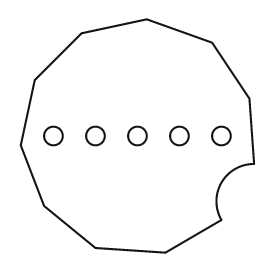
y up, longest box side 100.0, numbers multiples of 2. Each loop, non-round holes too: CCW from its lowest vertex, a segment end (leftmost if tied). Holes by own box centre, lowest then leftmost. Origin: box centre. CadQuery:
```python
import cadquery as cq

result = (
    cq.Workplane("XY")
    .moveTo(12.0, -50.0)
    .lineTo(36.0, -36.0)
    .threePointArc((36.0, -20.0), (50.0, -12.0))
    .lineTo(48.0, 16.0)
    .lineTo(32.0, 40.0)
    .lineTo(4.0, 50.0)
    .lineTo(-24.0, 44.0)
    .lineTo(-44.0, 24.0)
    .lineTo(-50.0, -4.0)
    .lineTo(-40.0, -30.0)
    .lineTo(-18.0, -48.0)
    .close()
    .moveTo(-36.0, 0.0)
    .circle(4.0)
    .moveTo(-18.0, 0.0)
    .circle(4.0)
    .moveTo(0.0, 0.0)
    .circle(4.0)
    .moveTo(18.0, 0.0)
    .circle(4.0)
    .moveTo(36.0, 0.0)
    .circle(4.0)
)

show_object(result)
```